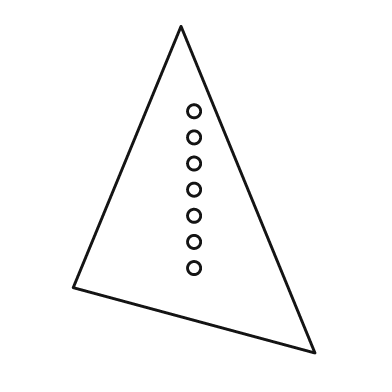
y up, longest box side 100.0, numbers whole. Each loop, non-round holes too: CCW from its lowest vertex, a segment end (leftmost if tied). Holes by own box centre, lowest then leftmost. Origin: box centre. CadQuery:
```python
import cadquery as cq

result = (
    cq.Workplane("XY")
    .moveTo(37.0, -50.0)
    .lineTo(-4.0, 50.0)
    .lineTo(-37.0, -30.0)
    .close()
    .moveTo(0.0, -24.0)
    .circle(2.0)
    .moveTo(0.0, -16.0)
    .circle(2.0)
    .moveTo(0.0, -8.0)
    .circle(2.0)
    .moveTo(0.0, 0.0)
    .circle(2.0)
    .moveTo(0.0, 8.0)
    .circle(2.0)
    .moveTo(0.0, 16.0)
    .circle(2.0)
    .moveTo(0.0, 24.0)
    .circle(2.0)
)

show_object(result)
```